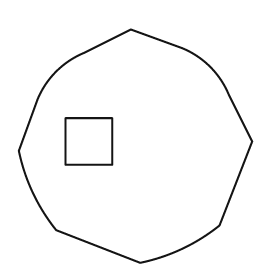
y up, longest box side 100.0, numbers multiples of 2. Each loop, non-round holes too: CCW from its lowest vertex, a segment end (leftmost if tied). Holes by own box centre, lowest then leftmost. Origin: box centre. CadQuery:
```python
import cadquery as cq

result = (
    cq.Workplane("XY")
    .moveTo(2.0, -50.0)
    .threePointArc((20.0, -44.0), (36.0, -34.0))
    .lineTo(50.0, 2.0)
    .lineTo(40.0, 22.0)
    .threePointArc((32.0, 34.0), (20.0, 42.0))
    .lineTo(-2.0, 50.0)
    .lineTo(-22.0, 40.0)
    .threePointArc((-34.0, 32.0), (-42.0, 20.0))
    .lineTo(-50.0, -2.0)
    .threePointArc((-44.0, -20.0), (-34.0, -36.0))
    .close()
    .moveTo(-30.0, -8.0)
    .lineTo(-10.0, -8.0)
    .lineTo(-10.0, 12.0)
    .lineTo(-30.0, 12.0)
    .close()
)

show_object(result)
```